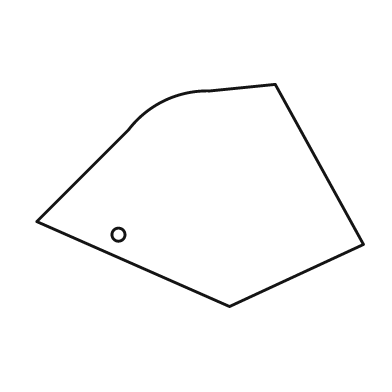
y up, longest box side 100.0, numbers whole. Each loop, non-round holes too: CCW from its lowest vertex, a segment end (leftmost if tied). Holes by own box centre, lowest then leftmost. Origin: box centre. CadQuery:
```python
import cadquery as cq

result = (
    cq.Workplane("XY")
    .moveTo(9.0, -34.0)
    .lineTo(50.0, -15.0)
    .lineTo(23.0, 34.0)
    .lineTo(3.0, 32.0)
    .threePointArc((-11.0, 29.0), (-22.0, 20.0))
    .lineTo(-50.0, -8.0)
    .close()
    .moveTo(-25.0, -12.0)
    .circle(2.0)
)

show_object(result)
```